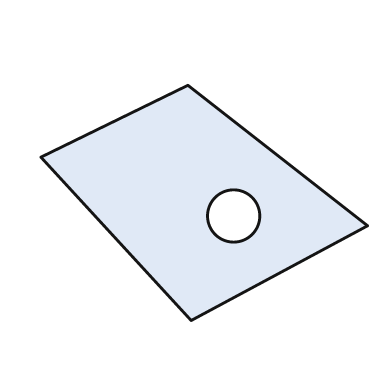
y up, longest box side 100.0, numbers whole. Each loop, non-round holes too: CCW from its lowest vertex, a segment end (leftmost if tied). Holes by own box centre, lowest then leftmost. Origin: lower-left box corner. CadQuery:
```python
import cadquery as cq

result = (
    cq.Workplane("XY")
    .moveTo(46.0, 0.0)
    .lineTo(100.0, 29.0)
    .lineTo(45.0, 72.0)
    .lineTo(0.0, 50.0)
    .close()
    .moveTo(59.0, 32.0)
    .circle(8.0)
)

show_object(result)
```